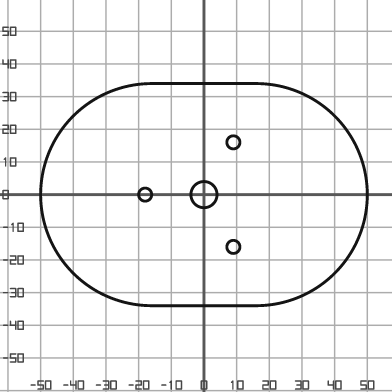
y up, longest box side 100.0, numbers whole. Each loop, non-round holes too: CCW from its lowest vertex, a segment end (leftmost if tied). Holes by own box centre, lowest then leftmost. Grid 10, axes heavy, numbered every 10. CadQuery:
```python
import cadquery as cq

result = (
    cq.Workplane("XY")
    .moveTo(-16.0, -34.0)
    .lineTo(16.0, -34.0)
    .threePointArc((50.0, 0.0), (16.0, 34.0))
    .lineTo(-16.0, 34.0)
    .threePointArc((-50.0, 0.0), (-16.0, -34.0))
    .close()
    .moveTo(9.0, -16.0)
    .circle(2.0)
    .moveTo(-18.0, 0.0)
    .circle(2.0)
    .moveTo(0.0, 0.0)
    .circle(4.0)
    .moveTo(9.0, 16.0)
    .circle(2.0)
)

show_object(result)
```